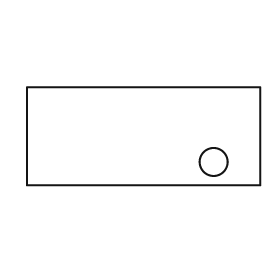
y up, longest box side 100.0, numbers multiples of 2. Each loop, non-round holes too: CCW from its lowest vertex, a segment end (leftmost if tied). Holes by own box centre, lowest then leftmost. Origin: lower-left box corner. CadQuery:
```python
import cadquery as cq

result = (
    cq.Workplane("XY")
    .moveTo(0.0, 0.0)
    .lineTo(100.0, 0.0)
    .lineTo(100.0, 42.0)
    .lineTo(0.0, 42.0)
    .close()
    .moveTo(80.0, 10.0)
    .circle(6.0)
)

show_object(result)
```